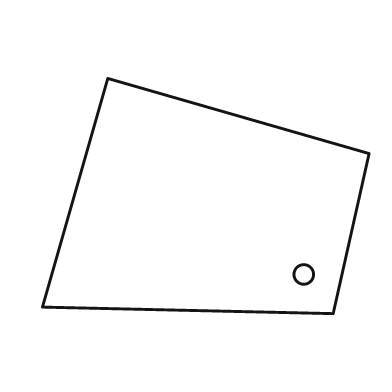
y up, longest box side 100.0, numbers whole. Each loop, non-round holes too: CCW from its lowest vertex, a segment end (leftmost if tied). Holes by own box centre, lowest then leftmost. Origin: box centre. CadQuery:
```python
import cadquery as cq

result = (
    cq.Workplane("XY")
    .moveTo(39.0, -36.0)
    .lineTo(50.0, 13.0)
    .lineTo(-30.0, 36.0)
    .lineTo(-50.0, -34.0)
    .close()
    .moveTo(30.0, -24.0)
    .circle(3.0)
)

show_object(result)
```